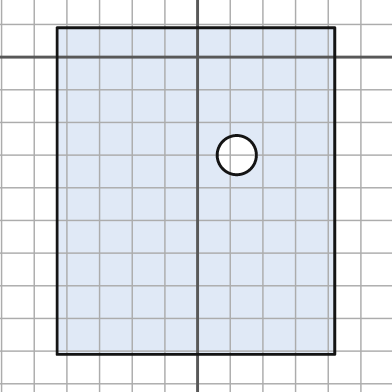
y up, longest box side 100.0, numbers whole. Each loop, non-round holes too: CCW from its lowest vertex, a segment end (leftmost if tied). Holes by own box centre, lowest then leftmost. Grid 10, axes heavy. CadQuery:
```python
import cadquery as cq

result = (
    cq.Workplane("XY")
    .moveTo(-43.0, -91.0)
    .lineTo(42.0, -91.0)
    .lineTo(42.0, 9.0)
    .lineTo(-43.0, 9.0)
    .close()
    .moveTo(12.0, -30.0)
    .circle(6.0)
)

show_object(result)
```